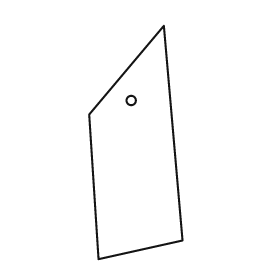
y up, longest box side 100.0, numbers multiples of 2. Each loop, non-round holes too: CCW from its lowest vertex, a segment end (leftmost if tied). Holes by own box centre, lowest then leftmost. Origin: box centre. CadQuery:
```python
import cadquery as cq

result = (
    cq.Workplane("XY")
    .moveTo(-16.0, -50.0)
    .lineTo(20.0, -42.0)
    .lineTo(12.0, 50.0)
    .lineTo(-20.0, 12.0)
    .close()
    .moveTo(-2.0, 18.0)
    .circle(2.0)
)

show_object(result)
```